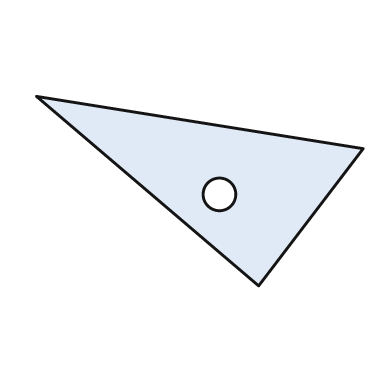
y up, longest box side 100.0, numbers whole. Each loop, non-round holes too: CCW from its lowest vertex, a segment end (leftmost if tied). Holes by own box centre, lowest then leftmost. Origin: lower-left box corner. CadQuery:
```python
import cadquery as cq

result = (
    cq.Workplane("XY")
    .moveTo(68.0, 0.0)
    .lineTo(100.0, 42.0)
    .lineTo(0.0, 58.0)
    .close()
    .moveTo(56.0, 28.0)
    .circle(5.0)
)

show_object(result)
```